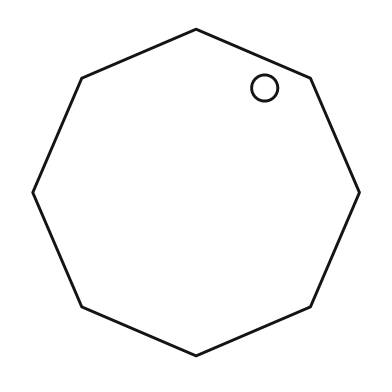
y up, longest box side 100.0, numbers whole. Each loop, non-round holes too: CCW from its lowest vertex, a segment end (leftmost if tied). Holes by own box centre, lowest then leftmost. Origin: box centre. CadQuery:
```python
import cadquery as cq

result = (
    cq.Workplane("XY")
    .moveTo(0.0, -50.0)
    .lineTo(35.0, -35.0)
    .lineTo(50.0, 0.0)
    .lineTo(35.0, 35.0)
    .lineTo(0.0, 50.0)
    .lineTo(-35.0, 35.0)
    .lineTo(-50.0, 0.0)
    .lineTo(-35.0, -35.0)
    .close()
    .moveTo(21.0, 32.0)
    .circle(4.0)
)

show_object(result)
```